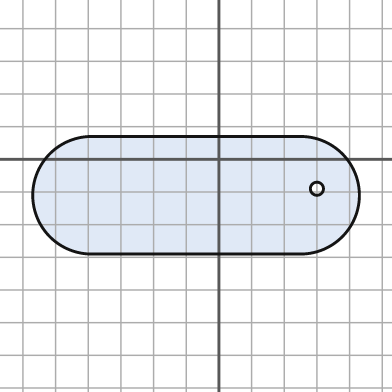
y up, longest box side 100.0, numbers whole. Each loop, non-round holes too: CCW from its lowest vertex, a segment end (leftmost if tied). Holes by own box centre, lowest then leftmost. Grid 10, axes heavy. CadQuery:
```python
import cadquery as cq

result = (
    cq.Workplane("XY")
    .moveTo(-39.0, -29.0)
    .lineTo(25.0, -29.0)
    .threePointArc((43.0, -11.0), (25.0, 7.0))
    .lineTo(-39.0, 7.0)
    .threePointArc((-57.0, -11.0), (-39.0, -29.0))
    .close()
    .moveTo(30.0, -9.0)
    .circle(2.0)
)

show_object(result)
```